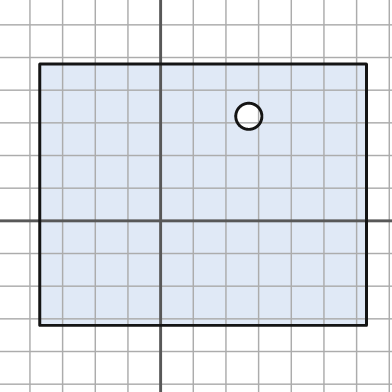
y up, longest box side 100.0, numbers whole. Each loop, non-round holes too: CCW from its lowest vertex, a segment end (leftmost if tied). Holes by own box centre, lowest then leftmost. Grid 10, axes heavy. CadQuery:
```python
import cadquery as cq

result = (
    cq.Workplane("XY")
    .moveTo(-37.0, -32.0)
    .lineTo(63.0, -32.0)
    .lineTo(63.0, 48.0)
    .lineTo(-37.0, 48.0)
    .close()
    .moveTo(27.0, 32.0)
    .circle(4.0)
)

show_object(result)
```